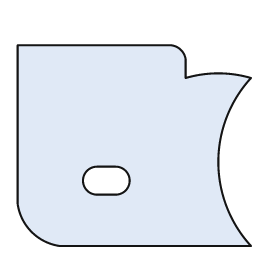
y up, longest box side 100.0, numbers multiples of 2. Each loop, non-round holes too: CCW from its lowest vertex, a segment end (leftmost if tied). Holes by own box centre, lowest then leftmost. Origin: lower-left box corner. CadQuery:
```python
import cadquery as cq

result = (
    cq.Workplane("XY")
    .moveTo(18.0, 0.0)
    .lineTo(100.0, 0.0)
    .threePointArc((86.0, 36.0), (100.0, 72.0))
    .threePointArc((86.0, 74.0), (72.0, 72.0))
    .lineTo(72.0, 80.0)
    .threePointArc((70.0, 84.0), (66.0, 86.0))
    .lineTo(0.0, 86.0)
    .lineTo(0.0, 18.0)
    .threePointArc((6.0, 6.0), (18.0, 0.0))
    .close()
    .moveTo(34.0, 22.0)
    .lineTo(42.0, 22.0)
    .threePointArc((48.0, 28.0), (42.0, 34.0))
    .lineTo(34.0, 34.0)
    .threePointArc((28.0, 28.0), (34.0, 22.0))
    .close()
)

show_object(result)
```